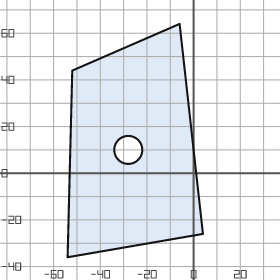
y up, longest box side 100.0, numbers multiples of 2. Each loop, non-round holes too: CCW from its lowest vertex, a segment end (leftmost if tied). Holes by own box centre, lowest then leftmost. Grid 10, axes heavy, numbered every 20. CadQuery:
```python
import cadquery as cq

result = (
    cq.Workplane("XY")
    .moveTo(-54.0, -36.0)
    .lineTo(4.0, -26.0)
    .lineTo(-6.0, 64.0)
    .lineTo(-52.0, 44.0)
    .close()
    .moveTo(-28.0, 10.0)
    .circle(6.0)
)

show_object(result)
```